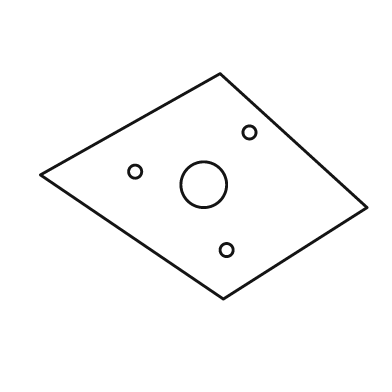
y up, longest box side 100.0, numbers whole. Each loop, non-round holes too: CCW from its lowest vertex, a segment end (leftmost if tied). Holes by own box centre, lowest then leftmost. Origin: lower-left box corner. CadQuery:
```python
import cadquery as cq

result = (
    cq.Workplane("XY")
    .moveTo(56.0, 0.0)
    .lineTo(100.0, 28.0)
    .lineTo(55.0, 69.0)
    .lineTo(0.0, 38.0)
    .close()
    .moveTo(57.0, 15.0)
    .circle(2.0)
    .moveTo(50.0, 35.0)
    .circle(7.0)
    .moveTo(29.0, 39.0)
    .circle(2.0)
    .moveTo(64.0, 51.0)
    .circle(2.0)
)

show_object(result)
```